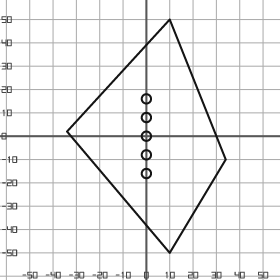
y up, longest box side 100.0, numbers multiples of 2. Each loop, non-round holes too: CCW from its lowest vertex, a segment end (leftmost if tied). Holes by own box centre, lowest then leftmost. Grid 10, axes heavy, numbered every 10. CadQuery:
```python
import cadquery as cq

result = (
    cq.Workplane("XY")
    .moveTo(10.0, -50.0)
    .lineTo(34.0, -10.0)
    .lineTo(10.0, 50.0)
    .lineTo(-34.0, 2.0)
    .close()
    .moveTo(0.0, -16.0)
    .circle(2.0)
    .moveTo(0.0, -8.0)
    .circle(2.0)
    .moveTo(0.0, 0.0)
    .circle(2.0)
    .moveTo(0.0, 8.0)
    .circle(2.0)
    .moveTo(0.0, 16.0)
    .circle(2.0)
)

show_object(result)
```